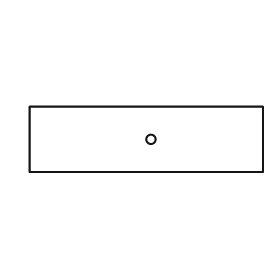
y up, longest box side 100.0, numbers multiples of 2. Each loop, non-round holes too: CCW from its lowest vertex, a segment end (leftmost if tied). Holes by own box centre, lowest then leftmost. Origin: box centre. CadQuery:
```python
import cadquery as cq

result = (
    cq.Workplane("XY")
    .moveTo(-50.0, -14.0)
    .lineTo(50.0, -14.0)
    .lineTo(50.0, 14.0)
    .lineTo(-50.0, 14.0)
    .close()
    .moveTo(2.0, 0.0)
    .circle(2.0)
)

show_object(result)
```